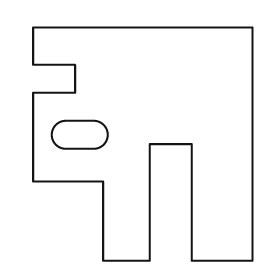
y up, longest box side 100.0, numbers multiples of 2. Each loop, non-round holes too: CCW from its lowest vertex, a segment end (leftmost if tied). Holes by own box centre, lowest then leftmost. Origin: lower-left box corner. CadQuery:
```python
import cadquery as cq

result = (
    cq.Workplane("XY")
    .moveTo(30.0, 0.0)
    .lineTo(50.0, 0.0)
    .lineTo(50.0, 50.0)
    .lineTo(68.0, 50.0)
    .lineTo(68.0, 0.0)
    .lineTo(94.0, 0.0)
    .lineTo(94.0, 100.0)
    .lineTo(0.0, 100.0)
    .lineTo(0.0, 84.0)
    .lineTo(18.0, 84.0)
    .lineTo(18.0, 72.0)
    .lineTo(0.0, 72.0)
    .lineTo(0.0, 34.0)
    .lineTo(30.0, 34.0)
    .close()
    .moveTo(14.0, 48.0)
    .lineTo(26.0, 48.0)
    .threePointArc((32.0, 54.0), (26.0, 60.0))
    .lineTo(14.0, 60.0)
    .threePointArc((8.0, 54.0), (14.0, 48.0))
    .close()
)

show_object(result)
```